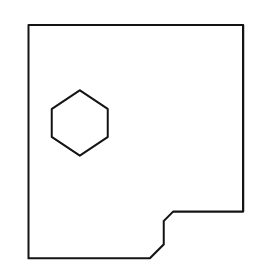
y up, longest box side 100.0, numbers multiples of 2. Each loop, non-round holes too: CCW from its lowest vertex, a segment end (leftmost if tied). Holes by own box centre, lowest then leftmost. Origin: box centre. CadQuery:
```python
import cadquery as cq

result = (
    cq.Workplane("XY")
    .moveTo(-46.0, -50.0)
    .lineTo(6.0, -50.0)
    .lineTo(12.0, -44.0)
    .lineTo(12.0, -34.0)
    .lineTo(16.0, -30.0)
    .lineTo(46.0, -30.0)
    .lineTo(46.0, 50.0)
    .lineTo(-46.0, 50.0)
    .close()
    .moveTo(-24.0, -6.0)
    .lineTo(-12.0, 2.0)
    .lineTo(-12.0, 14.0)
    .lineTo(-24.0, 22.0)
    .lineTo(-36.0, 14.0)
    .lineTo(-36.0, 2.0)
    .close()
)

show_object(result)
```